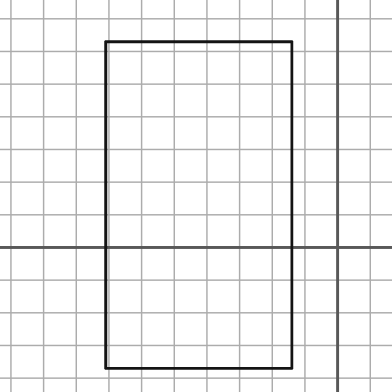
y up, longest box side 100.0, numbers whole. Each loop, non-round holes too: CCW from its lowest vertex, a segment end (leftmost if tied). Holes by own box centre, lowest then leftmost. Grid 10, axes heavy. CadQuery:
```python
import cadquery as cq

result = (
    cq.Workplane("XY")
    .moveTo(-71.0, -37.0)
    .lineTo(-14.0, -37.0)
    .lineTo(-14.0, 63.0)
    .lineTo(-71.0, 63.0)
    .close()
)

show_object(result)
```